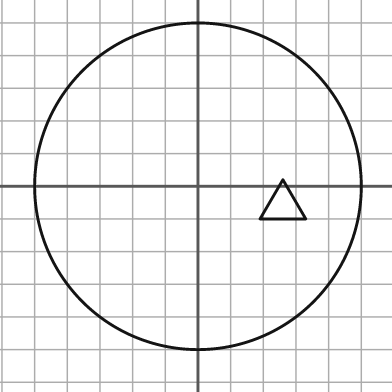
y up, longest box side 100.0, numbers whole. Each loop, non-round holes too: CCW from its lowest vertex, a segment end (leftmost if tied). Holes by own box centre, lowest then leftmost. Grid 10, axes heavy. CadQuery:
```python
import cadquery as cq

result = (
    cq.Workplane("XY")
    .moveTo(0.0, 0.0)
    .circle(50.0)
    .moveTo(19.0, -10.0)
    .lineTo(33.0, -10.0)
    .lineTo(26.0, 2.0)
    .close()
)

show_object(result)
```